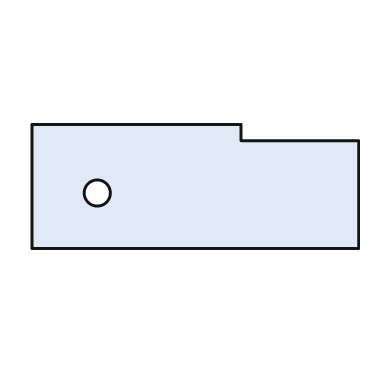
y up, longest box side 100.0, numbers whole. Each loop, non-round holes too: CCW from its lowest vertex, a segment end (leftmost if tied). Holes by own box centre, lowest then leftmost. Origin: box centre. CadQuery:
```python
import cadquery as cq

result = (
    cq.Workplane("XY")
    .moveTo(-50.0, -19.0)
    .lineTo(50.0, -19.0)
    .lineTo(50.0, 14.0)
    .lineTo(14.0, 14.0)
    .lineTo(14.0, 19.0)
    .lineTo(-50.0, 19.0)
    .close()
    .moveTo(-30.0, -2.0)
    .circle(4.0)
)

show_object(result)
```